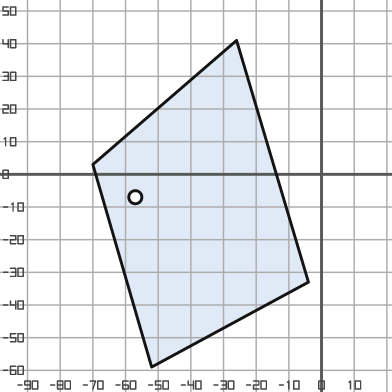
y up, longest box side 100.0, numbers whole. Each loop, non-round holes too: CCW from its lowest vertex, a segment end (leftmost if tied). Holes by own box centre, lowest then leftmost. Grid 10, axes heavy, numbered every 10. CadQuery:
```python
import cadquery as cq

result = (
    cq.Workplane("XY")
    .moveTo(-52.0, -59.0)
    .lineTo(-4.0, -33.0)
    .lineTo(-26.0, 41.0)
    .lineTo(-70.0, 3.0)
    .close()
    .moveTo(-57.0, -7.0)
    .circle(2.0)
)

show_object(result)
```